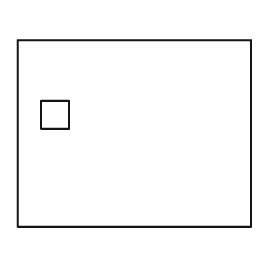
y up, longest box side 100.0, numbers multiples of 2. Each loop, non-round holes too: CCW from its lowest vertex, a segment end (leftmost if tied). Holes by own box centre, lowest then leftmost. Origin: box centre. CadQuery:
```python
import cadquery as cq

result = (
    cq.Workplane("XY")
    .moveTo(-50.0, -40.0)
    .lineTo(50.0, -40.0)
    .lineTo(50.0, 40.0)
    .lineTo(-50.0, 40.0)
    .close()
    .moveTo(-40.0, 2.0)
    .lineTo(-28.0, 2.0)
    .lineTo(-28.0, 14.0)
    .lineTo(-40.0, 14.0)
    .close()
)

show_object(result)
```